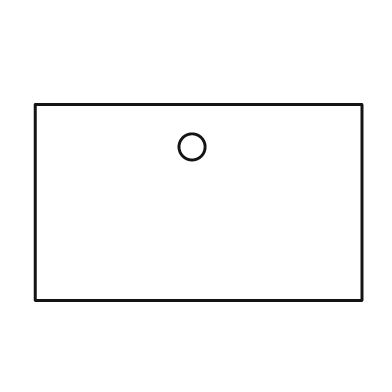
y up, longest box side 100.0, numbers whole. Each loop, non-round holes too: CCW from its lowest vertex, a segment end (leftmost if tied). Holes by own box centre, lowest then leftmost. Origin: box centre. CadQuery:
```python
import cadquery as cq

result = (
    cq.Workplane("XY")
    .moveTo(-50.0, -30.0)
    .lineTo(50.0, -30.0)
    .lineTo(50.0, 30.0)
    .lineTo(-50.0, 30.0)
    .close()
    .moveTo(-2.0, 17.0)
    .circle(4.0)
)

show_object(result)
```